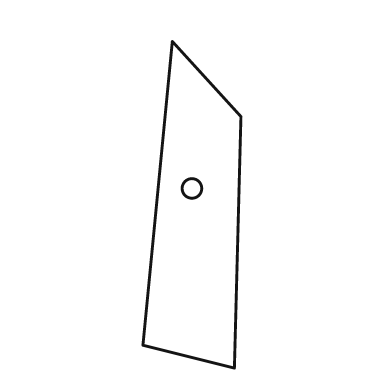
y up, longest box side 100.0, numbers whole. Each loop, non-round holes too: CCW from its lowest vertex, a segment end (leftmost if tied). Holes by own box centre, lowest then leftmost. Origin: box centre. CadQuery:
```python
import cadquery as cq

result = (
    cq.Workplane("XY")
    .moveTo(13.0, -50.0)
    .lineTo(15.0, 27.0)
    .lineTo(-6.0, 50.0)
    .lineTo(-15.0, -43.0)
    .close()
    .moveTo(0.0, 5.0)
    .circle(3.0)
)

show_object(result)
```